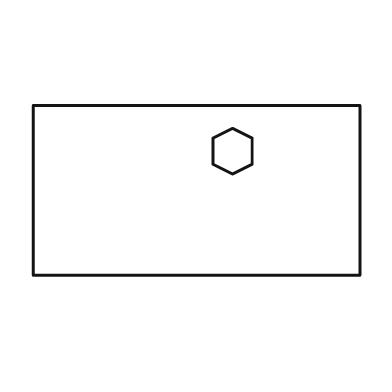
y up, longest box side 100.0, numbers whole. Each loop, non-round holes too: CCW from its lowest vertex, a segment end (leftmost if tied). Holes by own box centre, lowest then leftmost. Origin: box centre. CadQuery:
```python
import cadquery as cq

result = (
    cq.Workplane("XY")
    .moveTo(-50.0, -26.0)
    .lineTo(50.0, -26.0)
    .lineTo(50.0, 26.0)
    .lineTo(-50.0, 26.0)
    .close()
    .moveTo(11.0, 5.0)
    .lineTo(17.0, 8.0)
    .lineTo(17.0, 16.0)
    .lineTo(11.0, 19.0)
    .lineTo(5.0, 16.0)
    .lineTo(5.0, 8.0)
    .close()
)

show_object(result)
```